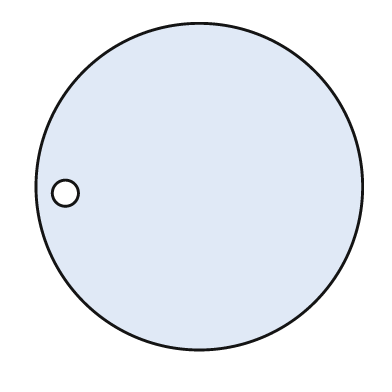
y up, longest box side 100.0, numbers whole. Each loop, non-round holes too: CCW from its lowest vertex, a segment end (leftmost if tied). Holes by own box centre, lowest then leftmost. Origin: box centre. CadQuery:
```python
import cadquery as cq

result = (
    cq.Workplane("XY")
    .moveTo(0.0, 0.0)
    .circle(50.0)
    .moveTo(-41.0, -2.0)
    .circle(4.0)
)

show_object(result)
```